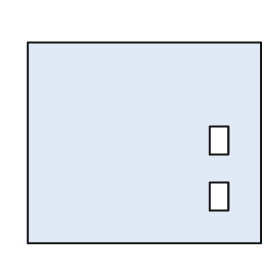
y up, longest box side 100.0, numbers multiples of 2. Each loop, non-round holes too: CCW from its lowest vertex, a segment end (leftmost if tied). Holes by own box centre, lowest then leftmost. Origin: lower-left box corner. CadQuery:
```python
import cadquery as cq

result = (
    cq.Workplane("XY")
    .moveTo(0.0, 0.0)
    .lineTo(100.0, 0.0)
    .lineTo(100.0, 86.0)
    .lineTo(0.0, 86.0)
    .close()
    .moveTo(78.0, 14.0)
    .lineTo(86.0, 14.0)
    .lineTo(86.0, 26.0)
    .lineTo(78.0, 26.0)
    .close()
    .moveTo(78.0, 38.0)
    .lineTo(86.0, 38.0)
    .lineTo(86.0, 50.0)
    .lineTo(78.0, 50.0)
    .close()
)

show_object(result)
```